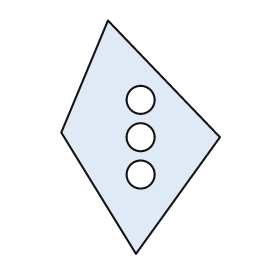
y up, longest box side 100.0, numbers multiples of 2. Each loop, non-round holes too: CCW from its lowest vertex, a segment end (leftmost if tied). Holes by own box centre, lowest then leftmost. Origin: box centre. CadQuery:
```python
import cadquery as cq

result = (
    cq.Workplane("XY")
    .moveTo(-2.0, -50.0)
    .lineTo(34.0, 0.0)
    .lineTo(-14.0, 50.0)
    .lineTo(-34.0, 2.0)
    .close()
    .moveTo(0.0, -16.0)
    .circle(6.0)
    .moveTo(0.0, 0.0)
    .circle(6.0)
    .moveTo(0.0, 16.0)
    .circle(6.0)
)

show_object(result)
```